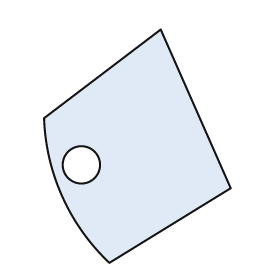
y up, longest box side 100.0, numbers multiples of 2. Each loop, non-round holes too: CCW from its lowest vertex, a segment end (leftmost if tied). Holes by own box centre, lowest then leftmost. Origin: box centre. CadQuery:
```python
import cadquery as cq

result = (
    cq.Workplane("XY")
    .moveTo(-12.0, -50.0)
    .lineTo(40.0, -18.0)
    .lineTo(10.0, 50.0)
    .lineTo(-40.0, 12.0)
    .threePointArc((-32.0, -22.0), (-12.0, -50.0))
    .close()
    .moveTo(-24.0, -8.0)
    .circle(8.0)
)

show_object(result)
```